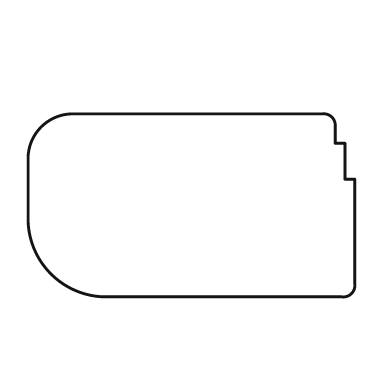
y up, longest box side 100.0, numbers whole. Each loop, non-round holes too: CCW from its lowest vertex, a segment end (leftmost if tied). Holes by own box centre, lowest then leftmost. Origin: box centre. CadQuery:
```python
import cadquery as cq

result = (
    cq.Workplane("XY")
    .moveTo(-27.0, -28.0)
    .lineTo(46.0, -28.0)
    .threePointArc((49.0, -27.0), (50.0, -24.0))
    .lineTo(50.0, 8.0)
    .lineTo(47.0, 8.0)
    .lineTo(47.0, 19.0)
    .lineTo(44.0, 19.0)
    .lineTo(44.0, 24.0)
    .threePointArc((43.0, 27.0), (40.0, 28.0))
    .lineTo(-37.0, 28.0)
    .threePointArc((-46.0, 24.0), (-50.0, 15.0))
    .lineTo(-50.0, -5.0)
    .threePointArc((-43.0, -21.0), (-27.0, -28.0))
    .close()
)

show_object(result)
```